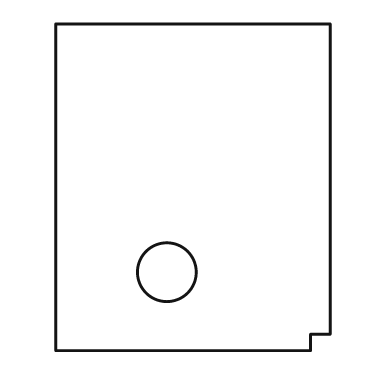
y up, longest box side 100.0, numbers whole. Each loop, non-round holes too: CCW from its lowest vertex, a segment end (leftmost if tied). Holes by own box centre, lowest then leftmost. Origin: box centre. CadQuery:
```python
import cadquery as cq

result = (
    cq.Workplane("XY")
    .moveTo(-42.0, -50.0)
    .lineTo(36.0, -50.0)
    .lineTo(36.0, -45.0)
    .lineTo(42.0, -45.0)
    .lineTo(42.0, 50.0)
    .lineTo(-42.0, 50.0)
    .close()
    .moveTo(-8.0, -26.0)
    .circle(9.0)
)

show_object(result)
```